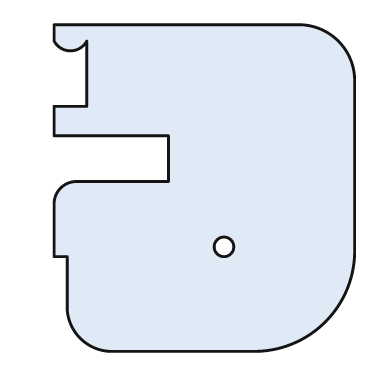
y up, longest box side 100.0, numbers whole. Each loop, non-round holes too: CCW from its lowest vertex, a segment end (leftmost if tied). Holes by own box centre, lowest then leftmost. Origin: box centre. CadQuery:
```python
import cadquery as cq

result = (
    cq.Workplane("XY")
    .moveTo(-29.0, -50.0)
    .lineTo(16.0, -50.0)
    .threePointArc((37.0, -41.0), (46.0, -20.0))
    .lineTo(46.0, 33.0)
    .threePointArc((41.0, 45.0), (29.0, 50.0))
    .lineTo(-46.0, 50.0)
    .lineTo(-46.0, 45.0)
    .threePointArc((-41.0, 42.0), (-36.0, 45.0))
    .lineTo(-36.0, 25.0)
    .lineTo(-46.0, 25.0)
    .lineTo(-46.0, 16.0)
    .lineTo(-11.0, 16.0)
    .lineTo(-11.0, 2.0)
    .lineTo(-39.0, 2.0)
    .threePointArc((-44.0, 0.0), (-46.0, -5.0))
    .lineTo(-46.0, -21.0)
    .lineTo(-42.0, -21.0)
    .lineTo(-42.0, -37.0)
    .threePointArc((-38.0, -46.0), (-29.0, -50.0))
    .close()
    .moveTo(6.0, -18.0)
    .circle(3.0)
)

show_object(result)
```